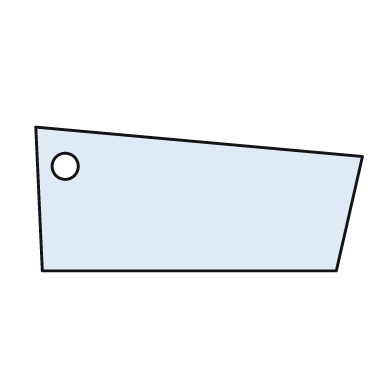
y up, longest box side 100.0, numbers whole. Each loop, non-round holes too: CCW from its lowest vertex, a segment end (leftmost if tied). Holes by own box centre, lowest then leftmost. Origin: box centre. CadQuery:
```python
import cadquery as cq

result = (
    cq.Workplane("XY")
    .moveTo(-48.0, -22.0)
    .lineTo(42.0, -22.0)
    .lineTo(50.0, 13.0)
    .lineTo(-50.0, 22.0)
    .close()
    .moveTo(-41.0, 10.0)
    .circle(4.0)
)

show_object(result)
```